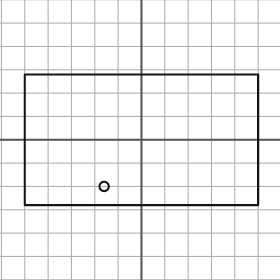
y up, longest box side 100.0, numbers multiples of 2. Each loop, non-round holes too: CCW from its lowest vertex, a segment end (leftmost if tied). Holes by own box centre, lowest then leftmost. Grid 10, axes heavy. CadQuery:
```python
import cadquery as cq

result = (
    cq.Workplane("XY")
    .moveTo(-50.0, -28.0)
    .lineTo(50.0, -28.0)
    .lineTo(50.0, 28.0)
    .lineTo(-50.0, 28.0)
    .close()
    .moveTo(-16.0, -20.0)
    .circle(2.0)
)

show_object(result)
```